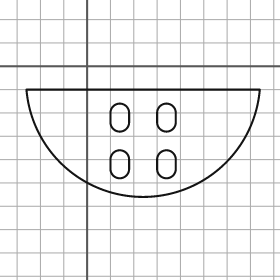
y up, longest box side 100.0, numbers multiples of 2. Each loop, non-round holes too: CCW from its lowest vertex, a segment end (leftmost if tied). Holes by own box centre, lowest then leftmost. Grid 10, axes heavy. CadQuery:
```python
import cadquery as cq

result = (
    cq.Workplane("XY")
    .moveTo(-26.0, -10.0)
    .threePointArc((24.0, -56.0), (74.0, -10.0))
    .close()
    .moveTo(10.0, -44.0)
    .threePointArc((14.0, -48.0), (18.0, -44.0))
    .lineTo(18.0, -40.0)
    .threePointArc((14.0, -36.0), (10.0, -40.0))
    .close()
    .moveTo(30.0, -44.0)
    .threePointArc((34.0, -48.0), (38.0, -44.0))
    .lineTo(38.0, -40.0)
    .threePointArc((34.0, -36.0), (30.0, -40.0))
    .close()
    .moveTo(10.0, -24.0)
    .threePointArc((14.0, -28.0), (18.0, -24.0))
    .lineTo(18.0, -20.0)
    .threePointArc((14.0, -16.0), (10.0, -20.0))
    .close()
    .moveTo(30.0, -24.0)
    .threePointArc((34.0, -28.0), (38.0, -24.0))
    .lineTo(38.0, -20.0)
    .threePointArc((34.0, -16.0), (30.0, -20.0))
    .close()
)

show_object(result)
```